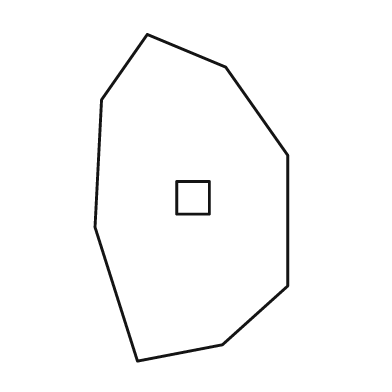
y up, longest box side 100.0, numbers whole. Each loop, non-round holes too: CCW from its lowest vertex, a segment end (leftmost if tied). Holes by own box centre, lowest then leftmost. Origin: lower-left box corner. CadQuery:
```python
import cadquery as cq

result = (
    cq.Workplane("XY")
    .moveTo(13.0, 0.0)
    .lineTo(39.0, 5.0)
    .lineTo(59.0, 23.0)
    .lineTo(59.0, 63.0)
    .lineTo(40.0, 90.0)
    .lineTo(16.0, 100.0)
    .lineTo(2.0, 80.0)
    .lineTo(0.0, 41.0)
    .close()
    .moveTo(25.0, 45.0)
    .lineTo(35.0, 45.0)
    .lineTo(35.0, 55.0)
    .lineTo(25.0, 55.0)
    .close()
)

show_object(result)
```